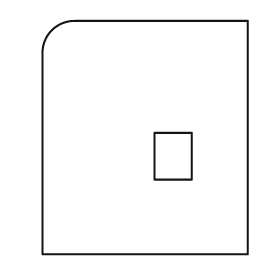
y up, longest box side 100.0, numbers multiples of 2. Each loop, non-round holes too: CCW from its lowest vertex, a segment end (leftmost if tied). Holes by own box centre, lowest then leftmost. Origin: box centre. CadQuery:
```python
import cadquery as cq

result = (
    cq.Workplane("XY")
    .moveTo(-44.0, -50.0)
    .lineTo(44.0, -50.0)
    .lineTo(44.0, 50.0)
    .lineTo(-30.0, 50.0)
    .threePointArc((-40.0, 46.0), (-44.0, 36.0))
    .close()
    .moveTo(4.0, -18.0)
    .lineTo(20.0, -18.0)
    .lineTo(20.0, 2.0)
    .lineTo(4.0, 2.0)
    .close()
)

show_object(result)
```